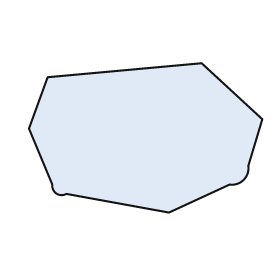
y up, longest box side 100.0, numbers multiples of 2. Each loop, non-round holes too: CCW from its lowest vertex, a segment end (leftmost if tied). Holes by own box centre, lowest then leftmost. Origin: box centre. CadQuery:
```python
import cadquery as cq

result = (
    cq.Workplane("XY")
    .moveTo(10.0, -32.0)
    .lineTo(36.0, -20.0)
    .threePointArc((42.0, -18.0), (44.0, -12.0))
    .lineTo(50.0, 8.0)
    .lineTo(24.0, 32.0)
    .lineTo(-42.0, 26.0)
    .lineTo(-50.0, 4.0)
    .lineTo(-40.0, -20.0)
    .threePointArc((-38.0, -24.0), (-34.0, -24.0))
    .close()
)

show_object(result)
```